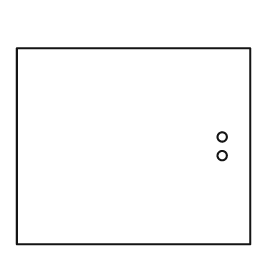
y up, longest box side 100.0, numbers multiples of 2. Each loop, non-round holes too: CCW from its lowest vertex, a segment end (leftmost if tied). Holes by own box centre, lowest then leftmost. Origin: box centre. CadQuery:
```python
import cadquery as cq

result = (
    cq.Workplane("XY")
    .moveTo(-50.0, -42.0)
    .lineTo(50.0, -42.0)
    .lineTo(50.0, 42.0)
    .lineTo(-50.0, 42.0)
    .close()
    .moveTo(38.0, -4.0)
    .circle(2.0)
    .moveTo(38.0, 4.0)
    .circle(2.0)
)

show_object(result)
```